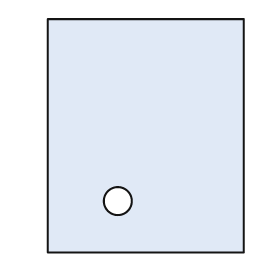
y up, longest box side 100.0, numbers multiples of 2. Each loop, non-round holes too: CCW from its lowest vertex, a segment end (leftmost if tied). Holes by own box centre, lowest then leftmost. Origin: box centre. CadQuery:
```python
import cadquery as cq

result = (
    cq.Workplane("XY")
    .moveTo(-42.0, -50.0)
    .lineTo(42.0, -50.0)
    .lineTo(42.0, 50.0)
    .lineTo(-42.0, 50.0)
    .close()
    .moveTo(-12.0, -28.0)
    .circle(6.0)
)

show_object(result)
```